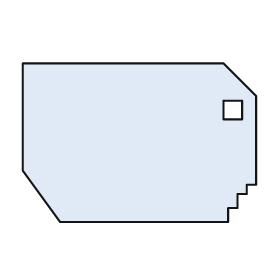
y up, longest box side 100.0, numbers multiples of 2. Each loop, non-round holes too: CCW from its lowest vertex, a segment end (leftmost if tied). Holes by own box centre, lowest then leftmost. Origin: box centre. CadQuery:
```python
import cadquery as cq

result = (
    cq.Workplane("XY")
    .moveTo(-34.0, -34.0)
    .lineTo(38.0, -34.0)
    .lineTo(38.0, -28.0)
    .lineTo(42.0, -28.0)
    .lineTo(42.0, -22.0)
    .lineTo(46.0, -22.0)
    .lineTo(46.0, -18.0)
    .lineTo(50.0, -18.0)
    .lineTo(50.0, 20.0)
    .lineTo(36.0, 34.0)
    .lineTo(-50.0, 34.0)
    .lineTo(-50.0, -12.0)
    .close()
    .moveTo(36.0, 10.0)
    .lineTo(44.0, 10.0)
    .lineTo(44.0, 18.0)
    .lineTo(36.0, 18.0)
    .close()
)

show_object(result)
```